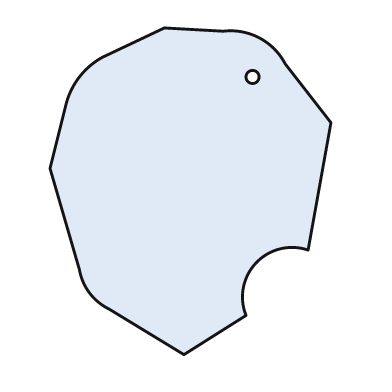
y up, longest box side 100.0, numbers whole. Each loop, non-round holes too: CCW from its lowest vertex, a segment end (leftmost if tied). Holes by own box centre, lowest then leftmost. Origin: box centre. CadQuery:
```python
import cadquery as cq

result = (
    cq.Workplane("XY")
    .moveTo(-2.0, -50.0)
    .lineTo(17.0, -38.0)
    .threePointArc((20.0, -22.0), (36.0, -18.0))
    .lineTo(43.0, 21.0)
    .lineTo(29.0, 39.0)
    .threePointArc((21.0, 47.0), (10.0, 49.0))
    .lineTo(-8.0, 50.0)
    .lineTo(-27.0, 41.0)
    .threePointArc((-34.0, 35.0), (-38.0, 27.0))
    .lineTo(-43.0, 7.0)
    .lineTo(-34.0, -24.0)
    .threePointArc((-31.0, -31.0), (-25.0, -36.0))
    .close()
    .moveTo(19.0, 35.0)
    .circle(2.0)
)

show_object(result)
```